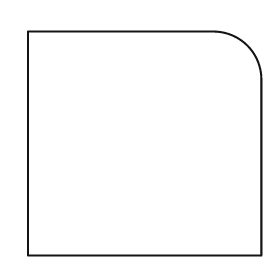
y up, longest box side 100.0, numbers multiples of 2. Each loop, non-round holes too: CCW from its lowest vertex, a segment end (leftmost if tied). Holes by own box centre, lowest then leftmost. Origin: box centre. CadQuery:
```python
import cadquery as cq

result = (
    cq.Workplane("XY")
    .moveTo(-50.0, -48.0)
    .lineTo(50.0, -48.0)
    .lineTo(50.0, 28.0)
    .threePointArc((44.0, 42.0), (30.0, 48.0))
    .lineTo(-50.0, 48.0)
    .close()
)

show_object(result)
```